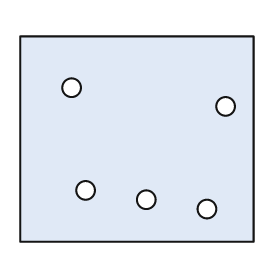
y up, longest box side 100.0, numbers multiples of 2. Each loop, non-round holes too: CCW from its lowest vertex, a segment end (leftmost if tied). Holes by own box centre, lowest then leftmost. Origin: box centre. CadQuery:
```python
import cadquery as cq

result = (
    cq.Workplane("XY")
    .moveTo(-50.0, -44.0)
    .lineTo(50.0, -44.0)
    .lineTo(50.0, 44.0)
    .lineTo(-50.0, 44.0)
    .close()
    .moveTo(30.0, -30.0)
    .circle(4.0)
    .moveTo(4.0, -26.0)
    .circle(4.0)
    .moveTo(-22.0, -22.0)
    .circle(4.0)
    .moveTo(38.0, 14.0)
    .circle(4.0)
    .moveTo(-28.0, 22.0)
    .circle(4.0)
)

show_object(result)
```